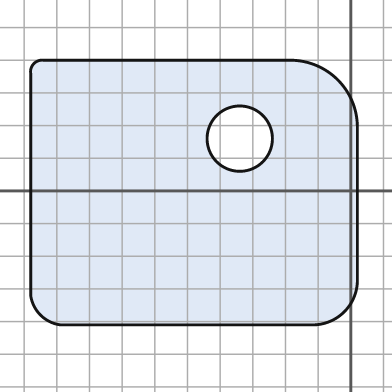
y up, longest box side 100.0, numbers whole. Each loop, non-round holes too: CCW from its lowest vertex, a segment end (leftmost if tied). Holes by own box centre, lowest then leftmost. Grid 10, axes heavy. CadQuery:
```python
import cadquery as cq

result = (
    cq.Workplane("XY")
    .moveTo(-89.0, -41.0)
    .lineTo(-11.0, -41.0)
    .threePointArc((-2.0, -37.0), (2.0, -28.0))
    .lineTo(2.0, 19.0)
    .threePointArc((-4.0, 34.0), (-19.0, 40.0))
    .lineTo(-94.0, 40.0)
    .threePointArc((-97.0, 39.0), (-98.0, 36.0))
    .lineTo(-98.0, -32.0)
    .threePointArc((-95.0, -38.0), (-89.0, -41.0))
    .close()
    .moveTo(-34.0, 16.0)
    .circle(10.0)
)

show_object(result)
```